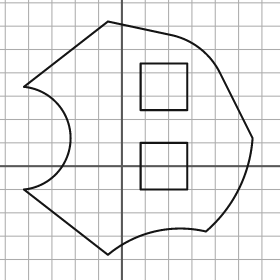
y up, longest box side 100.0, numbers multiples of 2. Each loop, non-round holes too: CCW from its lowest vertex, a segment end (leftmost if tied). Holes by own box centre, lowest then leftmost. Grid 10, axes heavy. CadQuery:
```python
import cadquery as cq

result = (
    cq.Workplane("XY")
    .moveTo(-6.0, -38.0)
    .threePointArc((14.0, -28.0), (36.0, -28.0))
    .threePointArc((50.0, -10.0), (56.0, 12.0))
    .lineTo(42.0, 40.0)
    .threePointArc((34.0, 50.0), (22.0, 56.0))
    .lineTo(-6.0, 62.0)
    .lineTo(-42.0, 34.0)
    .threePointArc((-22.0, 12.0), (-42.0, -10.0))
    .close()
    .moveTo(8.0, -10.0)
    .lineTo(28.0, -10.0)
    .lineTo(28.0, 10.0)
    .lineTo(8.0, 10.0)
    .close()
    .moveTo(8.0, 24.0)
    .lineTo(28.0, 24.0)
    .lineTo(28.0, 44.0)
    .lineTo(8.0, 44.0)
    .close()
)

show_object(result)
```